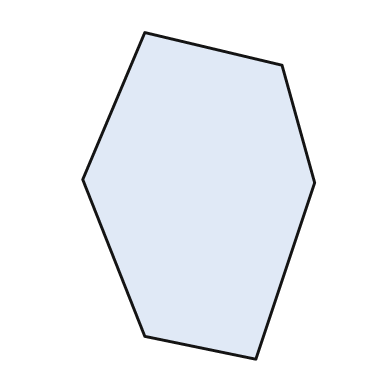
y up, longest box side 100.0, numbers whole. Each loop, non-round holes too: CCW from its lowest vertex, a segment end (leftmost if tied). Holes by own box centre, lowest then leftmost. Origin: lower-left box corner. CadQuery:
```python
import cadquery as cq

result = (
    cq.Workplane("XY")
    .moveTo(53.0, 0.0)
    .lineTo(71.0, 54.0)
    .lineTo(61.0, 90.0)
    .lineTo(19.0, 100.0)
    .lineTo(0.0, 55.0)
    .lineTo(19.0, 7.0)
    .close()
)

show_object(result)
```